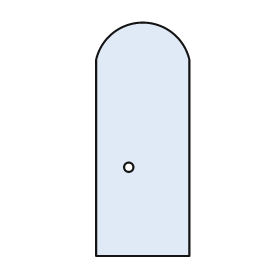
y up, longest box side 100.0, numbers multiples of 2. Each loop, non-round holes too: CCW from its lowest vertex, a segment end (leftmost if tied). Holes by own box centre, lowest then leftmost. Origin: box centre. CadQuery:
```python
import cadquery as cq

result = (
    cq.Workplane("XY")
    .moveTo(-20.0, -50.0)
    .lineTo(20.0, -50.0)
    .lineTo(20.0, 34.0)
    .threePointArc((0.0, 50.0), (-20.0, 34.0))
    .close()
    .moveTo(-6.0, -12.0)
    .circle(2.0)
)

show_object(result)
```